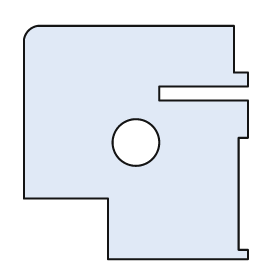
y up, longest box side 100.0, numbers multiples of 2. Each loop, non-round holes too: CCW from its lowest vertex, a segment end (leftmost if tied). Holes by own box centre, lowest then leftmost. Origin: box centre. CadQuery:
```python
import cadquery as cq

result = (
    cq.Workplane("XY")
    .moveTo(-12.0, -50.0)
    .lineTo(48.0, -50.0)
    .lineTo(48.0, -46.0)
    .lineTo(44.0, -46.0)
    .lineTo(44.0, 2.0)
    .lineTo(48.0, 2.0)
    .lineTo(48.0, 18.0)
    .lineTo(10.0, 18.0)
    .lineTo(10.0, 24.0)
    .lineTo(48.0, 24.0)
    .lineTo(48.0, 30.0)
    .lineTo(42.0, 30.0)
    .lineTo(42.0, 50.0)
    .lineTo(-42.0, 50.0)
    .threePointArc((-46.0, 48.0), (-48.0, 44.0))
    .lineTo(-48.0, -24.0)
    .lineTo(-12.0, -24.0)
    .close()
    .moveTo(0.0, 0.0)
    .circle(10.0)
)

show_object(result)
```